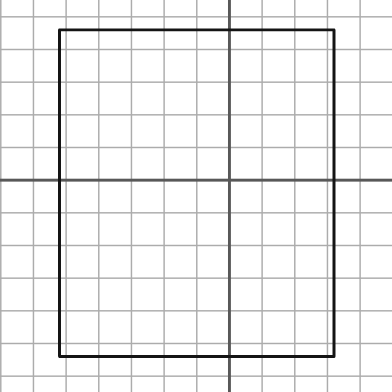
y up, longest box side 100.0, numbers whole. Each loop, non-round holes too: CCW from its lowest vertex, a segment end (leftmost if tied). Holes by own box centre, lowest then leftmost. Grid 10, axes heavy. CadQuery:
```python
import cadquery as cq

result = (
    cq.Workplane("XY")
    .moveTo(-52.0, -54.0)
    .lineTo(32.0, -54.0)
    .lineTo(32.0, 46.0)
    .lineTo(-52.0, 46.0)
    .close()
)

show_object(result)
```